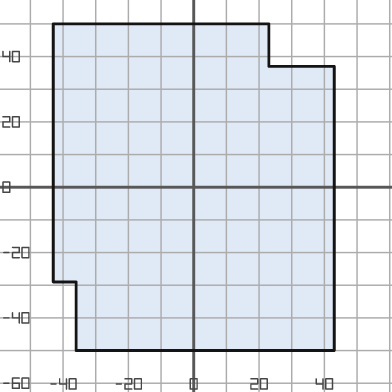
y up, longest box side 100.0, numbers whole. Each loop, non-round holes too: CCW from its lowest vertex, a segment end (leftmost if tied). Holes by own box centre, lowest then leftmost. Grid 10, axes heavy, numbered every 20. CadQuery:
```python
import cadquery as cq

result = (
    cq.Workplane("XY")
    .moveTo(-36.0, -50.0)
    .lineTo(43.0, -50.0)
    .lineTo(43.0, 37.0)
    .lineTo(23.0, 37.0)
    .lineTo(23.0, 50.0)
    .lineTo(-43.0, 50.0)
    .lineTo(-43.0, -29.0)
    .lineTo(-36.0, -29.0)
    .close()
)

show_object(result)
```